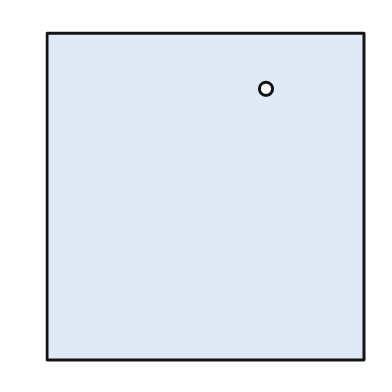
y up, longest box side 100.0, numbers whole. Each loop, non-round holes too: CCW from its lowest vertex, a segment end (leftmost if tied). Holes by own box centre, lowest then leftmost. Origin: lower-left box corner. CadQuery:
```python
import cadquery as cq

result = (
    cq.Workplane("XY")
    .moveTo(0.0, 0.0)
    .lineTo(97.0, 0.0)
    .lineTo(97.0, 100.0)
    .lineTo(0.0, 100.0)
    .close()
    .moveTo(67.0, 83.0)
    .circle(2.0)
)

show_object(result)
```